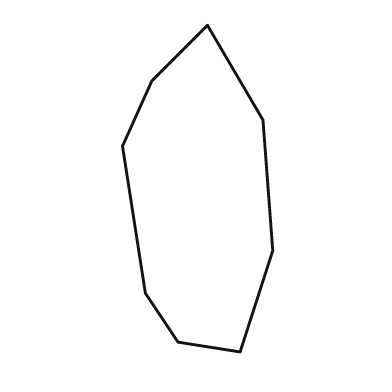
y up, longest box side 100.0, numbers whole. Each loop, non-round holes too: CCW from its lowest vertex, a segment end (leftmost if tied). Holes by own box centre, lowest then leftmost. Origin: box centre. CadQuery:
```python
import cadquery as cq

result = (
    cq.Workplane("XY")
    .moveTo(13.0, -50.0)
    .lineTo(23.0, -19.0)
    .lineTo(20.0, 21.0)
    .lineTo(3.0, 50.0)
    .lineTo(-14.0, 33.0)
    .lineTo(-23.0, 13.0)
    .lineTo(-16.0, -32.0)
    .lineTo(-6.0, -47.0)
    .close()
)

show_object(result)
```